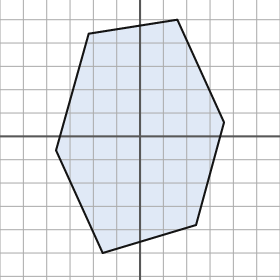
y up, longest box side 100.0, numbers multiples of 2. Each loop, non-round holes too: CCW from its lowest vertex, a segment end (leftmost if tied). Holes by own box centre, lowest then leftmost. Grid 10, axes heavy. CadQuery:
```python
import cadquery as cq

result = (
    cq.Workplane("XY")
    .moveTo(-16.0, -50.0)
    .lineTo(24.0, -38.0)
    .lineTo(36.0, 6.0)
    .lineTo(16.0, 50.0)
    .lineTo(-22.0, 44.0)
    .lineTo(-36.0, -6.0)
    .close()
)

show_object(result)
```